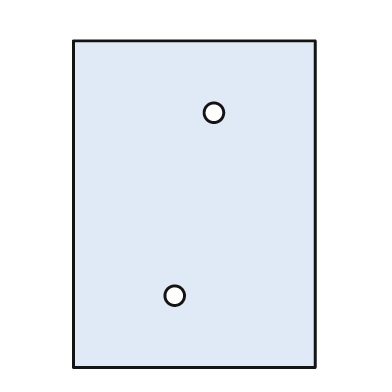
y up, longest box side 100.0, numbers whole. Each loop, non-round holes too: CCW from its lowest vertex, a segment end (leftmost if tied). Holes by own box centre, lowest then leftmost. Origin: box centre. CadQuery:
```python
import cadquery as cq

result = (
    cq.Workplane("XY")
    .moveTo(-37.0, -50.0)
    .lineTo(37.0, -50.0)
    .lineTo(37.0, 50.0)
    .lineTo(-37.0, 50.0)
    .close()
    .moveTo(-6.0, -28.0)
    .circle(3.0)
    .moveTo(6.0, 28.0)
    .circle(3.0)
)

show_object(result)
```